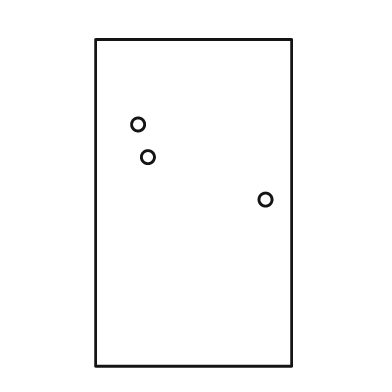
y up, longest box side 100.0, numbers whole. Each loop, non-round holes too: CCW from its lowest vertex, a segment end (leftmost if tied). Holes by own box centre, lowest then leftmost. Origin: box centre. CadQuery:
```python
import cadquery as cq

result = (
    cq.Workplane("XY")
    .moveTo(-30.0, -50.0)
    .lineTo(30.0, -50.0)
    .lineTo(30.0, 50.0)
    .lineTo(-30.0, 50.0)
    .close()
    .moveTo(22.0, 1.0)
    .circle(2.0)
    .moveTo(-14.0, 14.0)
    .circle(2.0)
    .moveTo(-17.0, 24.0)
    .circle(2.0)
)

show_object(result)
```